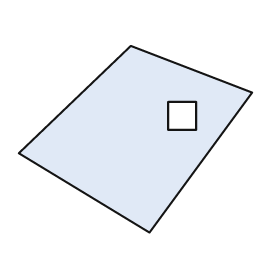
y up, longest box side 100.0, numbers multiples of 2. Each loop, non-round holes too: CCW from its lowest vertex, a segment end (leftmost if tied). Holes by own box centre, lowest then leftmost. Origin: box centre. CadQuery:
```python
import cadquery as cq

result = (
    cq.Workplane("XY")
    .moveTo(6.0, -40.0)
    .lineTo(50.0, 20.0)
    .lineTo(-2.0, 40.0)
    .lineTo(-50.0, -6.0)
    .close()
    .moveTo(14.0, 4.0)
    .lineTo(26.0, 4.0)
    .lineTo(26.0, 16.0)
    .lineTo(14.0, 16.0)
    .close()
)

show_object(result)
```